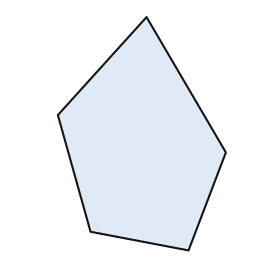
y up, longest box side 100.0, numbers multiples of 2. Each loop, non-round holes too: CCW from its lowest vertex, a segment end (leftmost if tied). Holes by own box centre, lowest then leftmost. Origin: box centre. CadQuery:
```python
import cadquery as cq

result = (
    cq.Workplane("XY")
    .moveTo(20.0, -50.0)
    .lineTo(36.0, -8.0)
    .lineTo(2.0, 50.0)
    .lineTo(-36.0, 8.0)
    .lineTo(-22.0, -42.0)
    .close()
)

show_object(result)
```